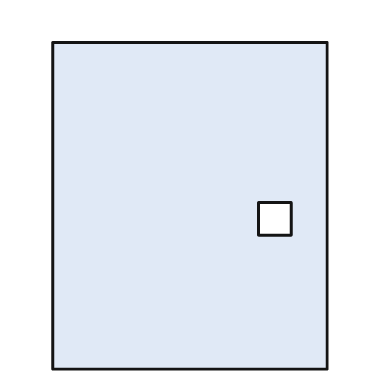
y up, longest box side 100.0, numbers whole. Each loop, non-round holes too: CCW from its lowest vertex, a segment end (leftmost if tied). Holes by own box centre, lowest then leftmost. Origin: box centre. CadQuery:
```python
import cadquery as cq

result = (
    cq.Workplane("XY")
    .moveTo(-42.0, -50.0)
    .lineTo(42.0, -50.0)
    .lineTo(42.0, 50.0)
    .lineTo(-42.0, 50.0)
    .close()
    .moveTo(21.0, -9.0)
    .lineTo(31.0, -9.0)
    .lineTo(31.0, 1.0)
    .lineTo(21.0, 1.0)
    .close()
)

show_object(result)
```